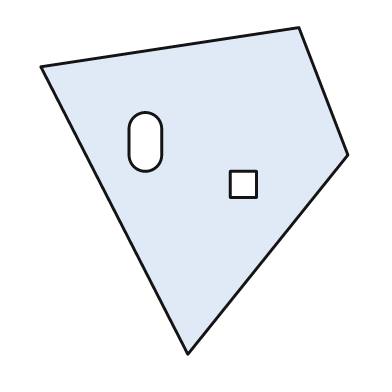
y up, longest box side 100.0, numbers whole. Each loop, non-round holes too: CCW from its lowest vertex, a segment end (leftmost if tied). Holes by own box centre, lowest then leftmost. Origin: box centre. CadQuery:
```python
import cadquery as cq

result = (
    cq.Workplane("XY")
    .moveTo(-2.0, -50.0)
    .lineTo(47.0, 11.0)
    .lineTo(32.0, 50.0)
    .lineTo(-47.0, 38.0)
    .close()
    .moveTo(11.0, -2.0)
    .lineTo(19.0, -2.0)
    .lineTo(19.0, 6.0)
    .lineTo(11.0, 6.0)
    .close()
    .moveTo(-20.0, 11.0)
    .threePointArc((-15.0, 6.0), (-10.0, 11.0))
    .lineTo(-10.0, 19.0)
    .threePointArc((-15.0, 24.0), (-20.0, 19.0))
    .close()
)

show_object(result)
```